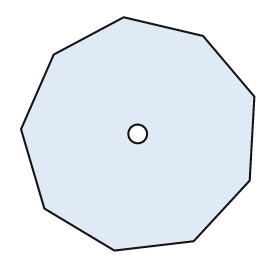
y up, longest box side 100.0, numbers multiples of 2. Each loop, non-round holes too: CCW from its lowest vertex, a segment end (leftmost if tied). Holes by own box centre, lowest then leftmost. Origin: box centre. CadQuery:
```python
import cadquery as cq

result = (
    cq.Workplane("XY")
    .moveTo(-10.0, -50.0)
    .lineTo(24.0, -46.0)
    .lineTo(48.0, -20.0)
    .lineTo(50.0, 16.0)
    .lineTo(28.0, 42.0)
    .lineTo(-6.0, 50.0)
    .lineTo(-36.0, 34.0)
    .lineTo(-50.0, 2.0)
    .lineTo(-40.0, -32.0)
    .close()
    .moveTo(0.0, 0.0)
    .circle(4.0)
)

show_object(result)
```